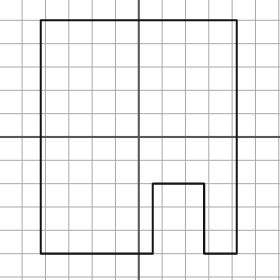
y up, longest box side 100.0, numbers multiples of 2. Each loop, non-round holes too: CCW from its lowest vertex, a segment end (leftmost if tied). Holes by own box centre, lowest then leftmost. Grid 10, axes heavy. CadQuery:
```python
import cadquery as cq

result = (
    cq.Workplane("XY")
    .moveTo(-42.0, -50.0)
    .lineTo(6.0, -50.0)
    .lineTo(6.0, -20.0)
    .lineTo(28.0, -20.0)
    .lineTo(28.0, -50.0)
    .lineTo(42.0, -50.0)
    .lineTo(42.0, 50.0)
    .lineTo(-42.0, 50.0)
    .close()
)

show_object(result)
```